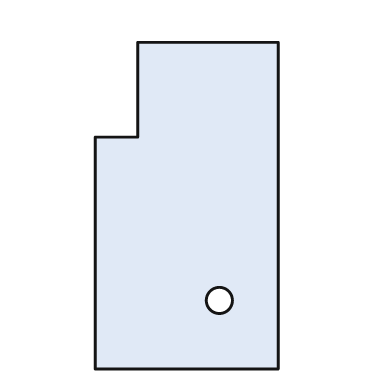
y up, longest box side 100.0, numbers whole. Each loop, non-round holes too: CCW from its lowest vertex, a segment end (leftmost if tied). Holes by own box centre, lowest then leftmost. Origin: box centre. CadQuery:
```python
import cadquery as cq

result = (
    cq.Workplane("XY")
    .moveTo(-28.0, -50.0)
    .lineTo(28.0, -50.0)
    .lineTo(28.0, 50.0)
    .lineTo(-15.0, 50.0)
    .lineTo(-15.0, 21.0)
    .lineTo(-28.0, 21.0)
    .close()
    .moveTo(10.0, -29.0)
    .circle(4.0)
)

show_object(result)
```